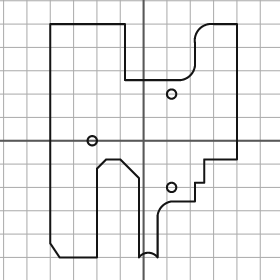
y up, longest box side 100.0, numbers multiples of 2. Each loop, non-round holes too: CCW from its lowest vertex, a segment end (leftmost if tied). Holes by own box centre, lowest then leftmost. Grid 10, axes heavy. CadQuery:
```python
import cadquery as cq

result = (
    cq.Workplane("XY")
    .moveTo(-36.0, -50.0)
    .lineTo(-20.0, -50.0)
    .lineTo(-20.0, -12.0)
    .lineTo(-16.0, -8.0)
    .lineTo(-10.0, -8.0)
    .lineTo(-2.0, -16.0)
    .lineTo(-2.0, -50.0)
    .threePointArc((2.0, -48.0), (6.0, -50.0))
    .lineTo(6.0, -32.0)
    .threePointArc((8.0, -28.0), (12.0, -26.0))
    .lineTo(22.0, -26.0)
    .lineTo(22.0, -18.0)
    .lineTo(26.0, -18.0)
    .lineTo(26.0, -8.0)
    .lineTo(40.0, -8.0)
    .lineTo(40.0, 50.0)
    .lineTo(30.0, 50.0)
    .threePointArc((24.0, 48.0), (22.0, 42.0))
    .lineTo(22.0, 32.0)
    .threePointArc((20.0, 28.0), (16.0, 26.0))
    .lineTo(-8.0, 26.0)
    .lineTo(-8.0, 50.0)
    .lineTo(-40.0, 50.0)
    .lineTo(-40.0, -44.0)
    .close()
    .moveTo(12.0, -20.0)
    .circle(2.0)
    .moveTo(-22.0, 0.0)
    .circle(2.0)
    .moveTo(12.0, 20.0)
    .circle(2.0)
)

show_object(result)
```